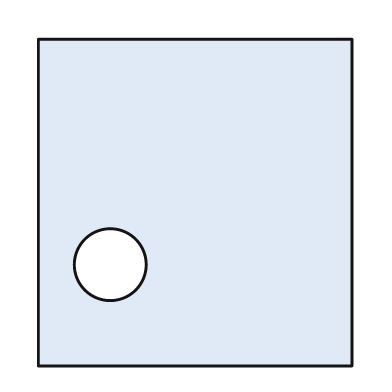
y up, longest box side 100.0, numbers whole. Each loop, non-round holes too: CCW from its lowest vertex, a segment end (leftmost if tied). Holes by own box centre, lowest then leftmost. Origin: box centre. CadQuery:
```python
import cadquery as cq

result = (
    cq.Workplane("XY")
    .moveTo(-48.0, -50.0)
    .lineTo(48.0, -50.0)
    .lineTo(48.0, 50.0)
    .lineTo(-48.0, 50.0)
    .close()
    .moveTo(-26.0, -19.0)
    .circle(11.0)
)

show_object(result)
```